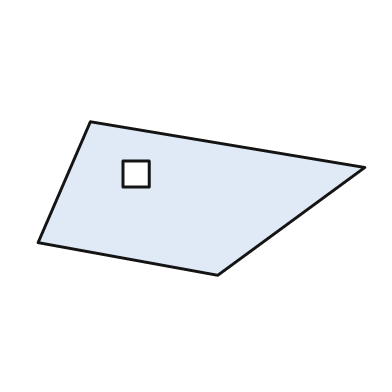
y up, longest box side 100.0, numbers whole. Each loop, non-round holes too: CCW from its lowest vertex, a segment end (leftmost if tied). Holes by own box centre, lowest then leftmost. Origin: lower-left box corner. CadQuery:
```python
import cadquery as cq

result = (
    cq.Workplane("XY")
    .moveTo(55.0, 0.0)
    .lineTo(100.0, 33.0)
    .lineTo(16.0, 47.0)
    .lineTo(0.0, 10.0)
    .close()
    .moveTo(26.0, 27.0)
    .lineTo(34.0, 27.0)
    .lineTo(34.0, 35.0)
    .lineTo(26.0, 35.0)
    .close()
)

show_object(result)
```